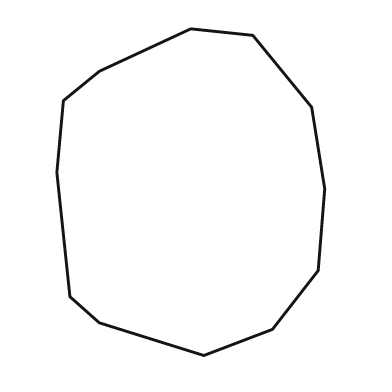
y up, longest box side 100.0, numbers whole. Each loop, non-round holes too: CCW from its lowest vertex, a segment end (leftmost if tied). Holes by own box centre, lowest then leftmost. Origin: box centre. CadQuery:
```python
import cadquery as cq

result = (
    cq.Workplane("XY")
    .moveTo(4.0, -50.0)
    .lineTo(25.0, -42.0)
    .lineTo(39.0, -24.0)
    .lineTo(41.0, 1.0)
    .lineTo(37.0, 26.0)
    .lineTo(19.0, 48.0)
    .lineTo(0.0, 50.0)
    .lineTo(-28.0, 37.0)
    .lineTo(-39.0, 28.0)
    .lineTo(-41.0, 6.0)
    .lineTo(-37.0, -32.0)
    .lineTo(-28.0, -40.0)
    .close()
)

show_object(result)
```